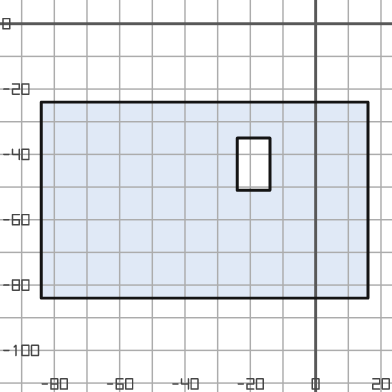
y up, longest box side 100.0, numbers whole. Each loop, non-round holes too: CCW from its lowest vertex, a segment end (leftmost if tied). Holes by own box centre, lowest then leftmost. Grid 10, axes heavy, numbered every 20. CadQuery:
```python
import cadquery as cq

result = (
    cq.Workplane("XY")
    .moveTo(-84.0, -84.0)
    .lineTo(16.0, -84.0)
    .lineTo(16.0, -24.0)
    .lineTo(-84.0, -24.0)
    .close()
    .moveTo(-24.0, -51.0)
    .lineTo(-14.0, -51.0)
    .lineTo(-14.0, -35.0)
    .lineTo(-24.0, -35.0)
    .close()
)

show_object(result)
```